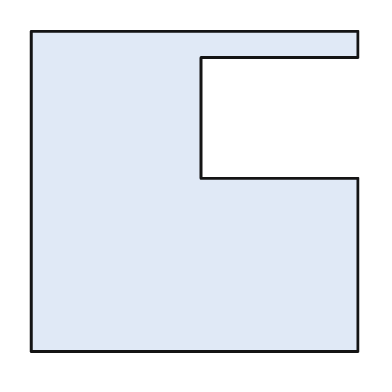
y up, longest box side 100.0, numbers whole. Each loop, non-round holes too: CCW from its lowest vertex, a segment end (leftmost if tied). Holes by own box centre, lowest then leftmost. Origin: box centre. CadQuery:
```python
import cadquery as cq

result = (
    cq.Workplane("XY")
    .moveTo(-50.0, -49.0)
    .lineTo(50.0, -49.0)
    .lineTo(50.0, 4.0)
    .lineTo(2.0, 4.0)
    .lineTo(2.0, 41.0)
    .lineTo(50.0, 41.0)
    .lineTo(50.0, 49.0)
    .lineTo(-50.0, 49.0)
    .close()
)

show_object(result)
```